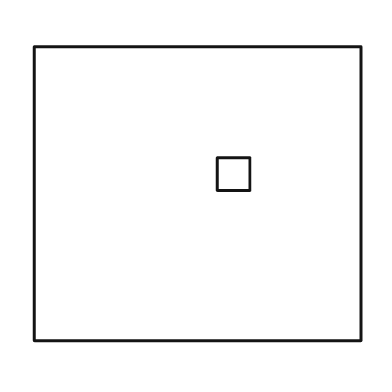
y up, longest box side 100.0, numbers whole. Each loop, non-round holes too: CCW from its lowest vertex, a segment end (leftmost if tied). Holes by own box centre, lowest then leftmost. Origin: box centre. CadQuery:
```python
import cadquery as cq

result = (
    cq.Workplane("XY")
    .moveTo(-50.0, -45.0)
    .lineTo(50.0, -45.0)
    .lineTo(50.0, 45.0)
    .lineTo(-50.0, 45.0)
    .close()
    .moveTo(6.0, 1.0)
    .lineTo(16.0, 1.0)
    .lineTo(16.0, 11.0)
    .lineTo(6.0, 11.0)
    .close()
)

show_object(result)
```